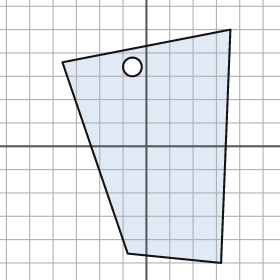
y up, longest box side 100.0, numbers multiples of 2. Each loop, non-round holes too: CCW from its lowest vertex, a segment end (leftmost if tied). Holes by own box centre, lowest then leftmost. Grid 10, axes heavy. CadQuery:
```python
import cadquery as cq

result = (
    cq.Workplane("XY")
    .moveTo(32.0, -50.0)
    .lineTo(36.0, 50.0)
    .lineTo(-36.0, 36.0)
    .lineTo(-8.0, -46.0)
    .close()
    .moveTo(-6.0, 34.0)
    .circle(4.0)
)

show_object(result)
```